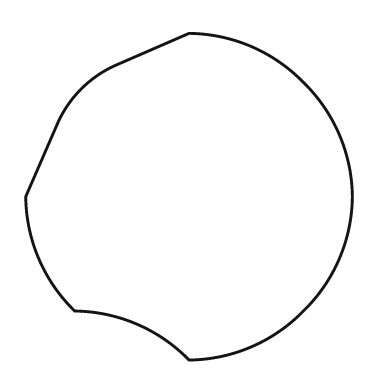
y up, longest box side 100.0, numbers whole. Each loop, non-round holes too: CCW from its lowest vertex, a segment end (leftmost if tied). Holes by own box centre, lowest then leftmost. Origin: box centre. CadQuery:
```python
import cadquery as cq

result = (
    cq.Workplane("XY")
    .moveTo(0.0, -50.0)
    .threePointArc((19.0, -46.0), (35.0, -35.0))
    .threePointArc((46.0, -19.0), (50.0, 0.0))
    .threePointArc((46.0, 19.0), (35.0, 35.0))
    .threePointArc((19.0, 46.0), (0.0, 50.0))
    .lineTo(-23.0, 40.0)
    .threePointArc((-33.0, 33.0), (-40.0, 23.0))
    .lineTo(-50.0, 0.0)
    .threePointArc((-46.0, -19.0), (-35.0, -35.0))
    .threePointArc((-16.0, -39.0), (0.0, -50.0))
    .close()
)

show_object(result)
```